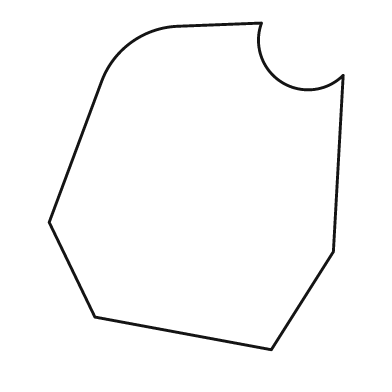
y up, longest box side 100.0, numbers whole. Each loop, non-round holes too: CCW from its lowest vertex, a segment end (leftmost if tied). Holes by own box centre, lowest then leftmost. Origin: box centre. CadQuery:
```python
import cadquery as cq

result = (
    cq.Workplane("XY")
    .moveTo(23.0, -50.0)
    .lineTo(42.0, -20.0)
    .lineTo(45.0, 34.0)
    .threePointArc((26.0, 32.0), (20.0, 50.0))
    .lineTo(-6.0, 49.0)
    .threePointArc((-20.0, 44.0), (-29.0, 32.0))
    .lineTo(-45.0, -11.0)
    .lineTo(-31.0, -40.0)
    .close()
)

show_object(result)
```